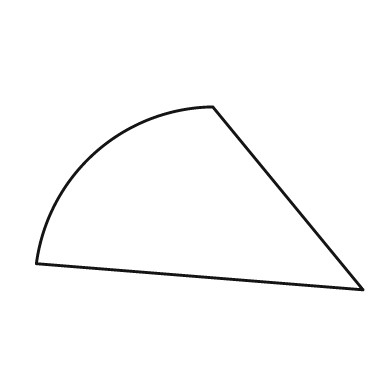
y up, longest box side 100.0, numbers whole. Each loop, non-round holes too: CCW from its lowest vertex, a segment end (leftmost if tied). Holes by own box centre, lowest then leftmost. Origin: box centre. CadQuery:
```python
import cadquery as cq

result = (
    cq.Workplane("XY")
    .moveTo(50.0, -28.0)
    .lineTo(4.0, 28.0)
    .threePointArc((-32.0, 14.0), (-50.0, -20.0))
    .close()
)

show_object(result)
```